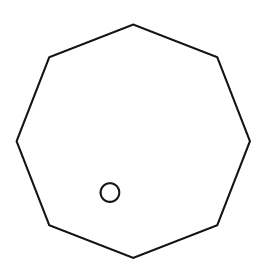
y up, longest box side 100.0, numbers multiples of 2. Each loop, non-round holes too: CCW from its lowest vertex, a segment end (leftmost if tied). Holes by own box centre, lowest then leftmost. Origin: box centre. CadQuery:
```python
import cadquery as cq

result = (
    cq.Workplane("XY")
    .moveTo(0.0, -50.0)
    .lineTo(36.0, -36.0)
    .lineTo(50.0, 0.0)
    .lineTo(36.0, 36.0)
    .lineTo(0.0, 50.0)
    .lineTo(-36.0, 36.0)
    .lineTo(-50.0, 0.0)
    .lineTo(-36.0, -36.0)
    .close()
    .moveTo(-10.0, -22.0)
    .circle(4.0)
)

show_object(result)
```